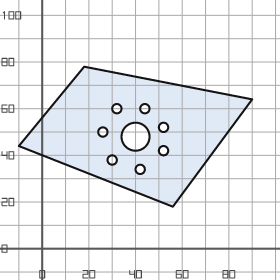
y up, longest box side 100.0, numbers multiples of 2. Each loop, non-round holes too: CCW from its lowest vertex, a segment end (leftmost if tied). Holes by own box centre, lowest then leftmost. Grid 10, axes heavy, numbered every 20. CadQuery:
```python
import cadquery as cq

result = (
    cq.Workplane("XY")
    .moveTo(56.0, 18.0)
    .lineTo(90.0, 64.0)
    .lineTo(18.0, 78.0)
    .lineTo(-10.0, 44.0)
    .close()
    .moveTo(42.0, 34.0)
    .circle(2.0)
    .moveTo(30.0, 38.0)
    .circle(2.0)
    .moveTo(52.0, 42.0)
    .circle(2.0)
    .moveTo(40.0, 48.0)
    .circle(6.0)
    .moveTo(26.0, 50.0)
    .circle(2.0)
    .moveTo(52.0, 52.0)
    .circle(2.0)
    .moveTo(32.0, 60.0)
    .circle(2.0)
    .moveTo(44.0, 60.0)
    .circle(2.0)
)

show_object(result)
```